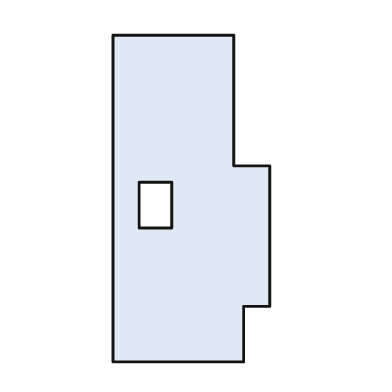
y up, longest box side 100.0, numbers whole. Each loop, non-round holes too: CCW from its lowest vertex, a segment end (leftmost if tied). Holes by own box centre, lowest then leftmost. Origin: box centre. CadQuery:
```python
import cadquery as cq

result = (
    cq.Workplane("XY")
    .moveTo(-24.0, -50.0)
    .lineTo(16.0, -50.0)
    .lineTo(16.0, -33.0)
    .lineTo(24.0, -33.0)
    .lineTo(24.0, 10.0)
    .lineTo(13.0, 10.0)
    .lineTo(13.0, 50.0)
    .lineTo(-24.0, 50.0)
    .close()
    .moveTo(-16.0, -9.0)
    .lineTo(-6.0, -9.0)
    .lineTo(-6.0, 5.0)
    .lineTo(-16.0, 5.0)
    .close()
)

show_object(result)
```